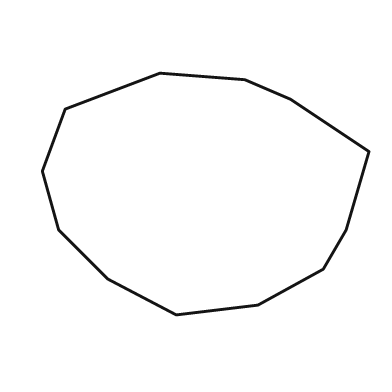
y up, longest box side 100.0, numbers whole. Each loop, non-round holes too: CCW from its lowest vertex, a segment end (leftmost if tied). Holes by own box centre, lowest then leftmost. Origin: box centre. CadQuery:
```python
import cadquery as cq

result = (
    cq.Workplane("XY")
    .moveTo(-9.0, -37.0)
    .lineTo(16.0, -34.0)
    .lineTo(36.0, -23.0)
    .lineTo(43.0, -11.0)
    .lineTo(50.0, 13.0)
    .lineTo(26.0, 29.0)
    .lineTo(12.0, 35.0)
    .lineTo(-14.0, 37.0)
    .lineTo(-43.0, 26.0)
    .lineTo(-50.0, 7.0)
    .lineTo(-45.0, -11.0)
    .lineTo(-30.0, -26.0)
    .close()
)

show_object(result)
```